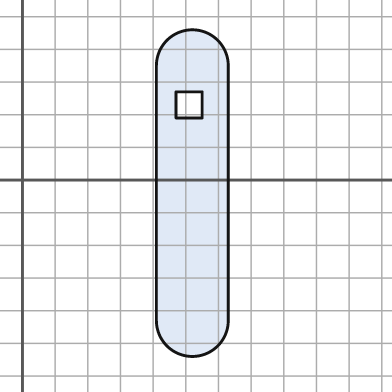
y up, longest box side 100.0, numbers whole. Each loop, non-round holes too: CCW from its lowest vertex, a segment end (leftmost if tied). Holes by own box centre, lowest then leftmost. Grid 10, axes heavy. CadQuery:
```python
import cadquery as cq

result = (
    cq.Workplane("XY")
    .moveTo(41.0, -43.0)
    .threePointArc((52.0, -54.0), (63.0, -43.0))
    .lineTo(63.0, 35.0)
    .threePointArc((52.0, 46.0), (41.0, 35.0))
    .close()
    .moveTo(47.0, 19.0)
    .lineTo(55.0, 19.0)
    .lineTo(55.0, 27.0)
    .lineTo(47.0, 27.0)
    .close()
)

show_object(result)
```